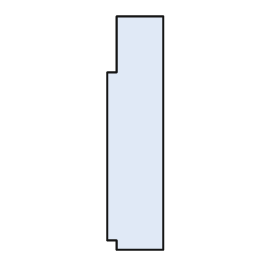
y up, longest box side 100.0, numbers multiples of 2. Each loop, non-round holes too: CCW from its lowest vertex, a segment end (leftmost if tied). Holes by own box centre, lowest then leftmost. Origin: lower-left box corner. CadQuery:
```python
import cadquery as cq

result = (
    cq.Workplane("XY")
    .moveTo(4.0, 0.0)
    .lineTo(24.0, 0.0)
    .lineTo(24.0, 100.0)
    .lineTo(4.0, 100.0)
    .lineTo(4.0, 76.0)
    .lineTo(0.0, 76.0)
    .lineTo(0.0, 4.0)
    .lineTo(4.0, 4.0)
    .close()
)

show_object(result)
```